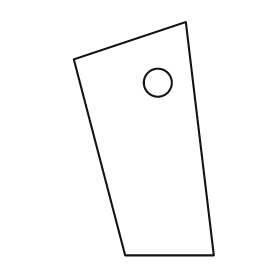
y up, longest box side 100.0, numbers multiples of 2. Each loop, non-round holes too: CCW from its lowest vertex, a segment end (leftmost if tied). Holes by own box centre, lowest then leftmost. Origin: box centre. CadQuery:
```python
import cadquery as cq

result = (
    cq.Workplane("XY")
    .moveTo(-8.0, -50.0)
    .lineTo(30.0, -50.0)
    .lineTo(18.0, 50.0)
    .lineTo(-30.0, 34.0)
    .close()
    .moveTo(6.0, 24.0)
    .circle(6.0)
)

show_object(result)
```